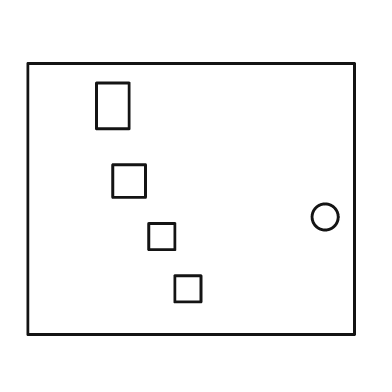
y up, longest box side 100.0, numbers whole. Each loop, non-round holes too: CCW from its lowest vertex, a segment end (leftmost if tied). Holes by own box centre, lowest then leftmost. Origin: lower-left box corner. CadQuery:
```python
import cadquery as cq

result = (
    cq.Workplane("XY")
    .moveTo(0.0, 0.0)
    .lineTo(100.0, 0.0)
    .lineTo(100.0, 83.0)
    .lineTo(0.0, 83.0)
    .close()
    .moveTo(45.0, 10.0)
    .lineTo(53.0, 10.0)
    .lineTo(53.0, 18.0)
    .lineTo(45.0, 18.0)
    .close()
    .moveTo(37.0, 26.0)
    .lineTo(45.0, 26.0)
    .lineTo(45.0, 34.0)
    .lineTo(37.0, 34.0)
    .close()
    .moveTo(91.0, 36.0)
    .circle(4.0)
    .moveTo(26.0, 42.0)
    .lineTo(36.0, 42.0)
    .lineTo(36.0, 52.0)
    .lineTo(26.0, 52.0)
    .close()
    .moveTo(21.0, 63.0)
    .lineTo(31.0, 63.0)
    .lineTo(31.0, 77.0)
    .lineTo(21.0, 77.0)
    .close()
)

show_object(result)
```